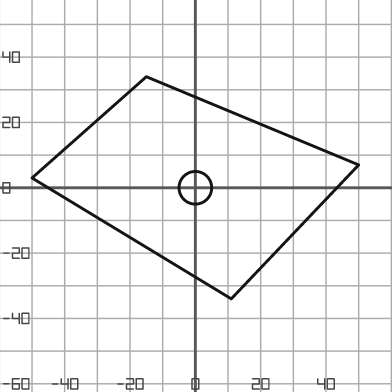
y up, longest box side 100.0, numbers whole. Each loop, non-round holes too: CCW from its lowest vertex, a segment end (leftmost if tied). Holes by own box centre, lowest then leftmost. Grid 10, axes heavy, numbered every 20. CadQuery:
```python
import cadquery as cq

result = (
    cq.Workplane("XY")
    .moveTo(11.0, -34.0)
    .lineTo(50.0, 7.0)
    .lineTo(-15.0, 34.0)
    .lineTo(-50.0, 3.0)
    .close()
    .moveTo(0.0, 0.0)
    .circle(5.0)
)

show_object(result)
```